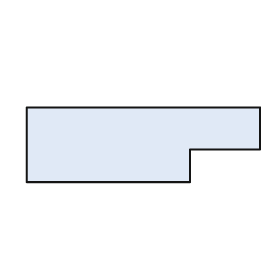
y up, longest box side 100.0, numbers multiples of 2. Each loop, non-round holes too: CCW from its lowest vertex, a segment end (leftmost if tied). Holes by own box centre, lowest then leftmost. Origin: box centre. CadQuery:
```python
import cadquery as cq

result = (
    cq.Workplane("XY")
    .moveTo(-50.0, -16.0)
    .lineTo(20.0, -16.0)
    .lineTo(20.0, -2.0)
    .lineTo(50.0, -2.0)
    .lineTo(50.0, 16.0)
    .lineTo(-50.0, 16.0)
    .close()
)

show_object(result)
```